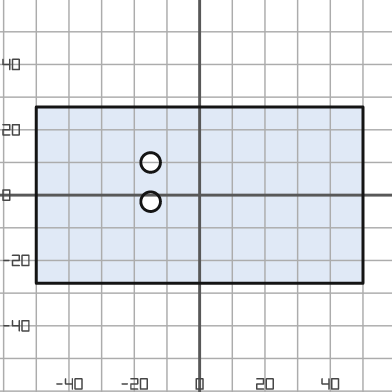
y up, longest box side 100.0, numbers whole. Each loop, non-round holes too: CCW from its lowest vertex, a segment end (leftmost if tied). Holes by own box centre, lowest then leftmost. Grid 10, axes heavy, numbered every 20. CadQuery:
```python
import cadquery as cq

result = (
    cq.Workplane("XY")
    .moveTo(-50.0, -27.0)
    .lineTo(50.0, -27.0)
    .lineTo(50.0, 27.0)
    .lineTo(-50.0, 27.0)
    .close()
    .moveTo(-15.0, -2.0)
    .circle(3.0)
    .moveTo(-15.0, 10.0)
    .circle(3.0)
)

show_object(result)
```